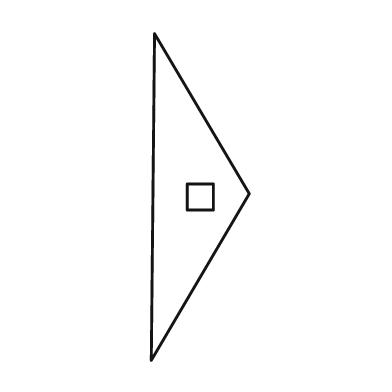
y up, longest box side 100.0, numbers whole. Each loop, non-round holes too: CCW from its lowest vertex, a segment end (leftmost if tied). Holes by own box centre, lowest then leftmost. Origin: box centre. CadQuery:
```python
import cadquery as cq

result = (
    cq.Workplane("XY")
    .moveTo(-15.0, -50.0)
    .lineTo(15.0, 1.0)
    .lineTo(-14.0, 50.0)
    .close()
    .moveTo(-4.0, -4.0)
    .lineTo(4.0, -4.0)
    .lineTo(4.0, 4.0)
    .lineTo(-4.0, 4.0)
    .close()
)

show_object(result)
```